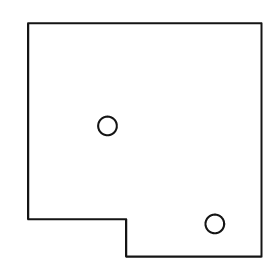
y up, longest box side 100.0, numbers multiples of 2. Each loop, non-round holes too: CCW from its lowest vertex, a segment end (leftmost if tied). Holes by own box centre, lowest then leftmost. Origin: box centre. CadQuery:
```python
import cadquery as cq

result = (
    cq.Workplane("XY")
    .moveTo(-8.0, -50.0)
    .lineTo(50.0, -50.0)
    .lineTo(50.0, 50.0)
    .lineTo(-50.0, 50.0)
    .lineTo(-50.0, -34.0)
    .lineTo(-8.0, -34.0)
    .close()
    .moveTo(30.0, -36.0)
    .circle(4.0)
    .moveTo(-16.0, 6.0)
    .circle(4.0)
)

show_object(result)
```